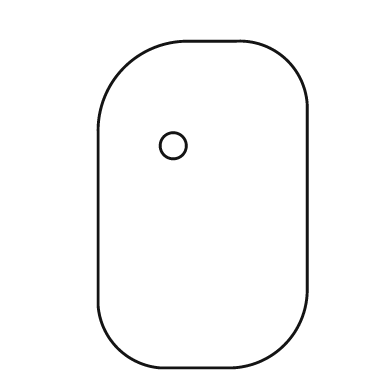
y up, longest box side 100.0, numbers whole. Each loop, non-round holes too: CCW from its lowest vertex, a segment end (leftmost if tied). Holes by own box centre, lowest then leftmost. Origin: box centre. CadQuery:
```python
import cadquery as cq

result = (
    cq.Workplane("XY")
    .moveTo(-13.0, -50.0)
    .lineTo(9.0, -50.0)
    .threePointArc((25.0, -43.0), (32.0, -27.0))
    .lineTo(32.0, 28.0)
    .threePointArc((26.0, 44.0), (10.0, 50.0))
    .lineTo(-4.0, 50.0)
    .threePointArc((-24.0, 42.0), (-32.0, 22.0))
    .lineTo(-32.0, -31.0)
    .threePointArc((-26.0, -44.0), (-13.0, -50.0))
    .close()
    .moveTo(-9.0, 18.0)
    .circle(4.0)
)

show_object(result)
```